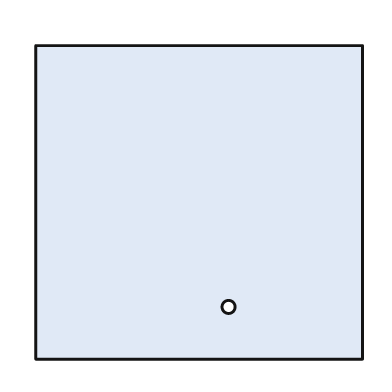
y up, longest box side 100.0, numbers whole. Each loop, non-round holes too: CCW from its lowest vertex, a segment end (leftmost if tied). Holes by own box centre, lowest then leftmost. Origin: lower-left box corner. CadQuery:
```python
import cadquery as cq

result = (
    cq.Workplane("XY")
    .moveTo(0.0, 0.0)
    .lineTo(100.0, 0.0)
    .lineTo(100.0, 96.0)
    .lineTo(0.0, 96.0)
    .close()
    .moveTo(59.0, 16.0)
    .circle(2.0)
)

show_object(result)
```